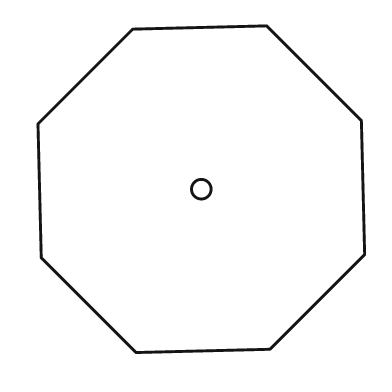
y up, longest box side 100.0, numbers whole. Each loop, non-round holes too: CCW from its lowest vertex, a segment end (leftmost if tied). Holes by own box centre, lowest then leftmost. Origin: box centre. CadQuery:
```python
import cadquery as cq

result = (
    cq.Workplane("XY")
    .moveTo(-20.0, -50.0)
    .lineTo(21.0, -49.0)
    .lineTo(50.0, -20.0)
    .lineTo(49.0, 21.0)
    .lineTo(20.0, 50.0)
    .lineTo(-21.0, 49.0)
    .lineTo(-50.0, 20.0)
    .lineTo(-49.0, -21.0)
    .close()
    .moveTo(0.0, 0.0)
    .circle(3.0)
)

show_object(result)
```